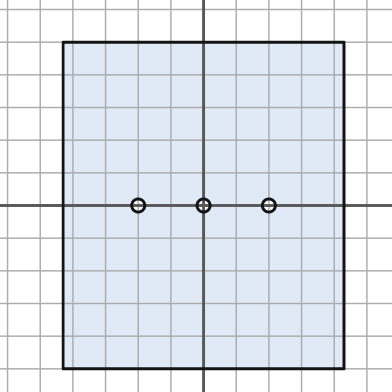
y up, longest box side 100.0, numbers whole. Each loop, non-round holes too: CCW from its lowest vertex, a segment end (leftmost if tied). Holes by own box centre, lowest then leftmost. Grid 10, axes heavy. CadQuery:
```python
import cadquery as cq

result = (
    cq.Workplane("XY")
    .moveTo(-43.0, -50.0)
    .lineTo(43.0, -50.0)
    .lineTo(43.0, 50.0)
    .lineTo(-43.0, 50.0)
    .close()
    .moveTo(-20.0, 0.0)
    .circle(2.0)
    .moveTo(0.0, 0.0)
    .circle(2.0)
    .moveTo(20.0, 0.0)
    .circle(2.0)
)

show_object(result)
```